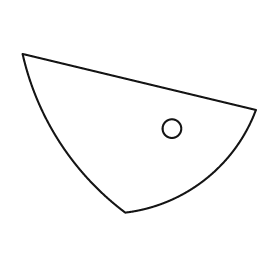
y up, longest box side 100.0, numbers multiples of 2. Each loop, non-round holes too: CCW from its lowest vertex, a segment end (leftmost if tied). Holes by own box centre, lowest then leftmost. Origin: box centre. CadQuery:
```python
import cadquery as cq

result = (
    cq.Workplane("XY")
    .moveTo(-6.0, -34.0)
    .threePointArc((28.0, -20.0), (50.0, 10.0))
    .lineTo(-50.0, 34.0)
    .threePointArc((-34.0, -4.0), (-6.0, -34.0))
    .close()
    .moveTo(14.0, 2.0)
    .circle(4.0)
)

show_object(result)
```